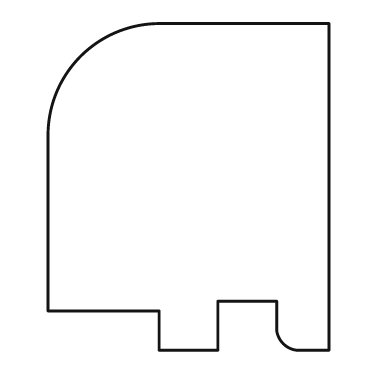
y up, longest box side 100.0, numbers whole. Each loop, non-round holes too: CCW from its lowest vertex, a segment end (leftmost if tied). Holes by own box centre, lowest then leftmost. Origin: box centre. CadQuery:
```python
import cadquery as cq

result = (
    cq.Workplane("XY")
    .moveTo(-9.0, -50.0)
    .lineTo(9.0, -50.0)
    .lineTo(9.0, -35.0)
    .lineTo(27.0, -35.0)
    .lineTo(27.0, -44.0)
    .threePointArc((29.0, -48.0), (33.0, -50.0))
    .lineTo(43.0, -50.0)
    .lineTo(43.0, 50.0)
    .lineTo(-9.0, 50.0)
    .threePointArc((-33.0, 40.0), (-43.0, 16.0))
    .lineTo(-43.0, -38.0)
    .lineTo(-9.0, -38.0)
    .close()
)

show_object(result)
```